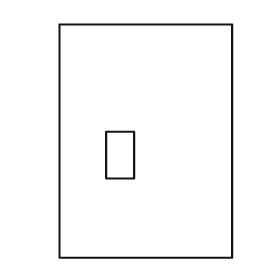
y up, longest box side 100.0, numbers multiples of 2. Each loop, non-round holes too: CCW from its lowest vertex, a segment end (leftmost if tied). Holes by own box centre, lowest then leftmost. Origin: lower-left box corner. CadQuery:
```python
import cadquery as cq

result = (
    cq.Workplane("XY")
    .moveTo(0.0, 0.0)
    .lineTo(74.0, 0.0)
    .lineTo(74.0, 100.0)
    .lineTo(0.0, 100.0)
    .close()
    .moveTo(20.0, 34.0)
    .lineTo(32.0, 34.0)
    .lineTo(32.0, 54.0)
    .lineTo(20.0, 54.0)
    .close()
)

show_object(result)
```